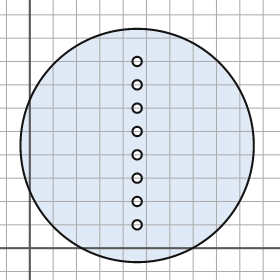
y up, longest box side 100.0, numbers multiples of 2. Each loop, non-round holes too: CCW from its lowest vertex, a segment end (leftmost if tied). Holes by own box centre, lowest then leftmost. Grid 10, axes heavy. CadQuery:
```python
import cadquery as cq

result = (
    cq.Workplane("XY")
    .moveTo(46.0, 44.0)
    .circle(50.0)
    .moveTo(46.0, 10.0)
    .circle(2.0)
    .moveTo(46.0, 20.0)
    .circle(2.0)
    .moveTo(46.0, 30.0)
    .circle(2.0)
    .moveTo(46.0, 40.0)
    .circle(2.0)
    .moveTo(46.0, 50.0)
    .circle(2.0)
    .moveTo(46.0, 60.0)
    .circle(2.0)
    .moveTo(46.0, 70.0)
    .circle(2.0)
    .moveTo(46.0, 80.0)
    .circle(2.0)
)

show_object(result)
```